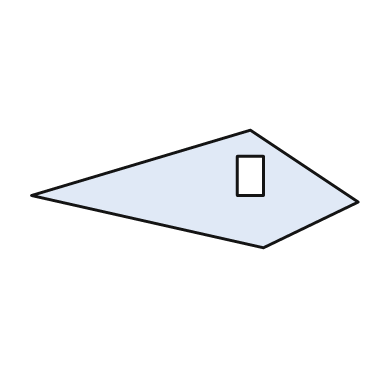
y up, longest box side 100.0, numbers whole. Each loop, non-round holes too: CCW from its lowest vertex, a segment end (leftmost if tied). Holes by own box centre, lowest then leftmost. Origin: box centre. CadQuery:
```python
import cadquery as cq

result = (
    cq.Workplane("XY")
    .moveTo(21.0, -18.0)
    .lineTo(50.0, -4.0)
    .lineTo(17.0, 18.0)
    .lineTo(-50.0, -2.0)
    .close()
    .moveTo(13.0, -2.0)
    .lineTo(21.0, -2.0)
    .lineTo(21.0, 10.0)
    .lineTo(13.0, 10.0)
    .close()
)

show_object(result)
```